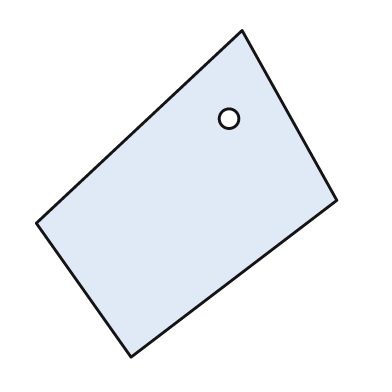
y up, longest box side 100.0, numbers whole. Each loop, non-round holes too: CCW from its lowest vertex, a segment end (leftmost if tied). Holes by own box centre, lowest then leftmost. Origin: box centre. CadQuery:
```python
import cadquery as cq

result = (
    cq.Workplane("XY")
    .moveTo(-17.0, -50.0)
    .lineTo(46.0, -2.0)
    .lineTo(17.0, 50.0)
    .lineTo(-46.0, -9.0)
    .close()
    .moveTo(13.0, 23.0)
    .circle(3.0)
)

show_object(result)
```